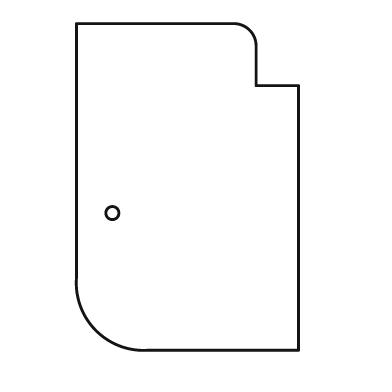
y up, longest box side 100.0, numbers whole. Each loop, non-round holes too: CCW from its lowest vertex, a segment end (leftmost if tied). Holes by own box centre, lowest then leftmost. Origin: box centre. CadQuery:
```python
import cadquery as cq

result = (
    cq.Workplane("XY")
    .moveTo(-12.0, -50.0)
    .lineTo(34.0, -50.0)
    .lineTo(34.0, 31.0)
    .lineTo(21.0, 31.0)
    .lineTo(21.0, 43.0)
    .threePointArc((19.0, 48.0), (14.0, 50.0))
    .lineTo(-34.0, 50.0)
    .lineTo(-34.0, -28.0)
    .threePointArc((-28.0, -44.0), (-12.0, -50.0))
    .close()
    .moveTo(-23.0, -8.0)
    .circle(2.0)
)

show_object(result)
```